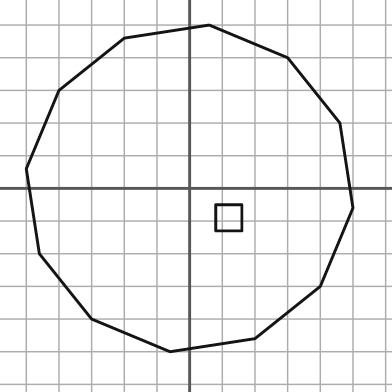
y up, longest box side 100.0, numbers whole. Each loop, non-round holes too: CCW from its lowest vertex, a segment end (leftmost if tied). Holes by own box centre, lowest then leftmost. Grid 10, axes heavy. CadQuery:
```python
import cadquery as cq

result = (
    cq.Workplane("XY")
    .moveTo(-6.0, -50.0)
    .lineTo(20.0, -46.0)
    .lineTo(40.0, -30.0)
    .lineTo(50.0, -6.0)
    .lineTo(46.0, 20.0)
    .lineTo(30.0, 40.0)
    .lineTo(6.0, 50.0)
    .lineTo(-20.0, 46.0)
    .lineTo(-40.0, 30.0)
    .lineTo(-50.0, 6.0)
    .lineTo(-46.0, -20.0)
    .lineTo(-30.0, -40.0)
    .close()
    .moveTo(8.0, -13.0)
    .lineTo(16.0, -13.0)
    .lineTo(16.0, -5.0)
    .lineTo(8.0, -5.0)
    .close()
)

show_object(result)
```